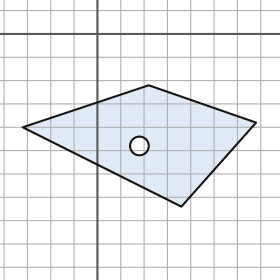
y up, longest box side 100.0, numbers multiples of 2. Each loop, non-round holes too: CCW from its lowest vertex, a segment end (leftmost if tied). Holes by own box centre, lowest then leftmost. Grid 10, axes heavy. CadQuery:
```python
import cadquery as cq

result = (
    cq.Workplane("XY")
    .moveTo(36.0, -74.0)
    .lineTo(68.0, -38.0)
    .lineTo(22.0, -22.0)
    .lineTo(-32.0, -40.0)
    .close()
    .moveTo(18.0, -48.0)
    .circle(4.0)
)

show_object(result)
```